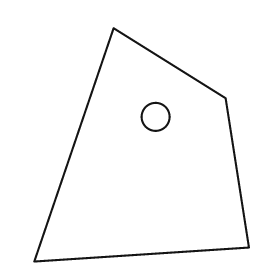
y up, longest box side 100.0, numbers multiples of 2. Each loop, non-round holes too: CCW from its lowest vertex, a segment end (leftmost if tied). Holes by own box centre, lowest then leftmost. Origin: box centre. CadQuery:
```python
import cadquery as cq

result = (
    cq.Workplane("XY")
    .moveTo(-46.0, -50.0)
    .lineTo(46.0, -44.0)
    .lineTo(36.0, 20.0)
    .lineTo(-12.0, 50.0)
    .close()
    .moveTo(6.0, 12.0)
    .circle(6.0)
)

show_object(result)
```